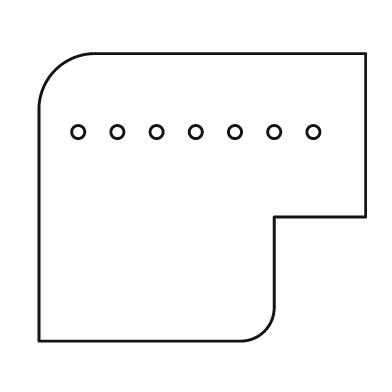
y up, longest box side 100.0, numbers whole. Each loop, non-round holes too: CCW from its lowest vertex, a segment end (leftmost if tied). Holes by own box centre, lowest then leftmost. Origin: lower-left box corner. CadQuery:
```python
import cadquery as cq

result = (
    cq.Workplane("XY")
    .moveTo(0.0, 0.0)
    .lineTo(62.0, 0.0)
    .threePointArc((69.0, 3.0), (72.0, 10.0))
    .lineTo(72.0, 38.0)
    .lineTo(100.0, 38.0)
    .lineTo(100.0, 88.0)
    .lineTo(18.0, 88.0)
    .threePointArc((5.0, 83.0), (0.0, 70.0))
    .close()
    .moveTo(12.0, 64.0)
    .circle(2.0)
    .moveTo(24.0, 64.0)
    .circle(2.0)
    .moveTo(36.0, 64.0)
    .circle(2.0)
    .moveTo(48.0, 64.0)
    .circle(2.0)
    .moveTo(60.0, 64.0)
    .circle(2.0)
    .moveTo(72.0, 64.0)
    .circle(2.0)
    .moveTo(84.0, 64.0)
    .circle(2.0)
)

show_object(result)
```